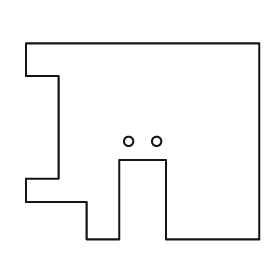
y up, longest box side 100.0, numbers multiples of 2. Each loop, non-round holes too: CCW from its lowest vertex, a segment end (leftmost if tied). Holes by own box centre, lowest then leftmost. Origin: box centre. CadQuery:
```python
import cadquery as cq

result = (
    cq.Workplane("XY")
    .moveTo(-24.0, -42.0)
    .lineTo(-10.0, -42.0)
    .lineTo(-10.0, -8.0)
    .lineTo(10.0, -8.0)
    .lineTo(10.0, -42.0)
    .lineTo(50.0, -42.0)
    .lineTo(50.0, 42.0)
    .lineTo(-50.0, 42.0)
    .lineTo(-50.0, 28.0)
    .lineTo(-36.0, 28.0)
    .lineTo(-36.0, -16.0)
    .lineTo(-50.0, -16.0)
    .lineTo(-50.0, -26.0)
    .lineTo(-24.0, -26.0)
    .close()
    .moveTo(-6.0, 0.0)
    .circle(2.0)
    .moveTo(6.0, 0.0)
    .circle(2.0)
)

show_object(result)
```